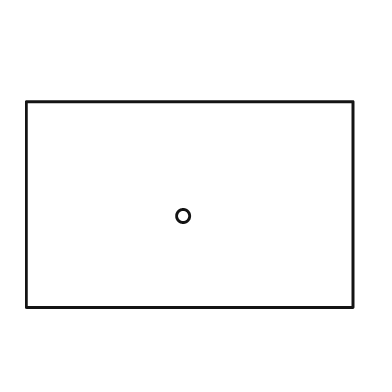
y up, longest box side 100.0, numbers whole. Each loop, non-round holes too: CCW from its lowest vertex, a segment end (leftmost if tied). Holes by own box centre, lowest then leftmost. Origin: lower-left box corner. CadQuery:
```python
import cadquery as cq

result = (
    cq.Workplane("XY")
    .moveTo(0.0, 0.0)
    .lineTo(100.0, 0.0)
    .lineTo(100.0, 63.0)
    .lineTo(0.0, 63.0)
    .close()
    .moveTo(48.0, 28.0)
    .circle(2.0)
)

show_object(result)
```